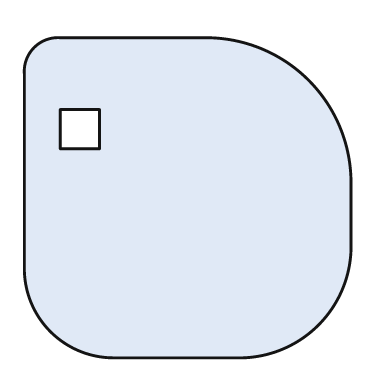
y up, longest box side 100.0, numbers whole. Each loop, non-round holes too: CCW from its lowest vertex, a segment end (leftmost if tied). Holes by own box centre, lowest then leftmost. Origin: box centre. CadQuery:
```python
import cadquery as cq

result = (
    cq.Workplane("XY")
    .moveTo(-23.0, -49.0)
    .lineTo(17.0, -49.0)
    .threePointArc((40.0, -39.0), (50.0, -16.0))
    .lineTo(50.0, 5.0)
    .threePointArc((37.0, 36.0), (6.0, 49.0))
    .lineTo(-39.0, 49.0)
    .threePointArc((-47.0, 46.0), (-50.0, 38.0))
    .lineTo(-50.0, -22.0)
    .threePointArc((-42.0, -41.0), (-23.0, -49.0))
    .close()
    .moveTo(-39.0, 15.0)
    .lineTo(-27.0, 15.0)
    .lineTo(-27.0, 27.0)
    .lineTo(-39.0, 27.0)
    .close()
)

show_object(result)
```